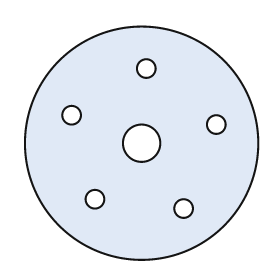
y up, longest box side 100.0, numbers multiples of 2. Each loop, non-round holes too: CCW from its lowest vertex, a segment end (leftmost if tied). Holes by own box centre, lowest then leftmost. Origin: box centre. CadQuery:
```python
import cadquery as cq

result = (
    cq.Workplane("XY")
    .moveTo(0.0, 0.0)
    .circle(50.0)
    .moveTo(18.0, -28.0)
    .circle(4.0)
    .moveTo(-20.0, -24.0)
    .circle(4.0)
    .moveTo(0.0, 0.0)
    .circle(8.0)
    .moveTo(32.0, 8.0)
    .circle(4.0)
    .moveTo(-30.0, 12.0)
    .circle(4.0)
    .moveTo(2.0, 32.0)
    .circle(4.0)
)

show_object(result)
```